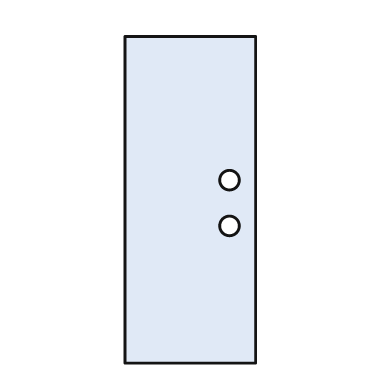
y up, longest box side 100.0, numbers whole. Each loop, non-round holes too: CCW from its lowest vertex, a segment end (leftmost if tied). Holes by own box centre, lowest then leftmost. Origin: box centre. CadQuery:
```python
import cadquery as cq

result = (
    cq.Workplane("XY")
    .moveTo(-20.0, -50.0)
    .lineTo(20.0, -50.0)
    .lineTo(20.0, 50.0)
    .lineTo(-20.0, 50.0)
    .close()
    .moveTo(12.0, -8.0)
    .circle(3.0)
    .moveTo(12.0, 6.0)
    .circle(3.0)
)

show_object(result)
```